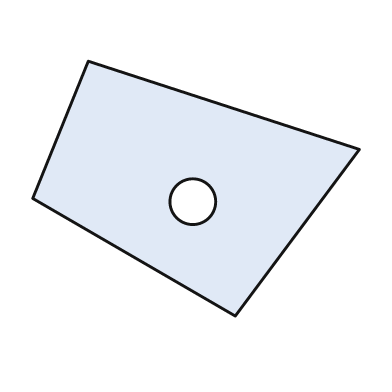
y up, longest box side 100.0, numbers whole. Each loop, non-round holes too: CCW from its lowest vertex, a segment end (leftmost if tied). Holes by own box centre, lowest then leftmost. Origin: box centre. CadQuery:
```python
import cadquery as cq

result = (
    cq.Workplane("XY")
    .moveTo(12.0, -39.0)
    .lineTo(50.0, 12.0)
    .lineTo(-33.0, 39.0)
    .lineTo(-50.0, -3.0)
    .close()
    .moveTo(-1.0, -4.0)
    .circle(7.0)
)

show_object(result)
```